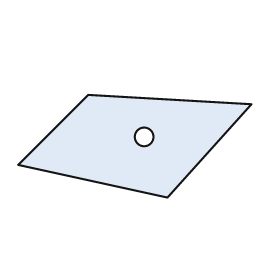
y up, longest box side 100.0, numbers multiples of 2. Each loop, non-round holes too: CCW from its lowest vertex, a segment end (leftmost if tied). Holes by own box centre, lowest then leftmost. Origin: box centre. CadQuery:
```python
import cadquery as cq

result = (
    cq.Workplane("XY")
    .moveTo(14.0, -22.0)
    .lineTo(50.0, 18.0)
    .lineTo(-20.0, 22.0)
    .lineTo(-50.0, -8.0)
    .close()
    .moveTo(4.0, 4.0)
    .circle(4.0)
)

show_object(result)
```